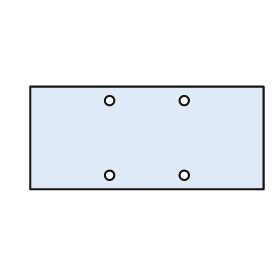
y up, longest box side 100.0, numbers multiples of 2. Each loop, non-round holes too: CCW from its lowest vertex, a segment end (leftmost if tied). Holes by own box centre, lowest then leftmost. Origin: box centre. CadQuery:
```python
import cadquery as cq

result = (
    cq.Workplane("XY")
    .moveTo(-50.0, -22.0)
    .lineTo(50.0, -22.0)
    .lineTo(50.0, 22.0)
    .lineTo(-50.0, 22.0)
    .close()
    .moveTo(-16.0, -16.0)
    .circle(2.0)
    .moveTo(16.0, -16.0)
    .circle(2.0)
    .moveTo(-16.0, 16.0)
    .circle(2.0)
    .moveTo(16.0, 16.0)
    .circle(2.0)
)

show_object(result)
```